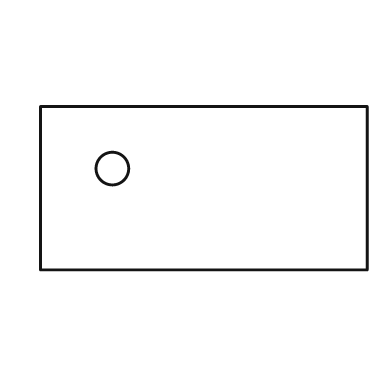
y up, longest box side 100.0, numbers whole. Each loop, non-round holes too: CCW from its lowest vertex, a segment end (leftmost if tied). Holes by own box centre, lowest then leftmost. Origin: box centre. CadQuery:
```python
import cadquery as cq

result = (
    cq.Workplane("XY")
    .moveTo(-50.0, -25.0)
    .lineTo(50.0, -25.0)
    .lineTo(50.0, 25.0)
    .lineTo(-50.0, 25.0)
    .close()
    .moveTo(-28.0, 6.0)
    .circle(5.0)
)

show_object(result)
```